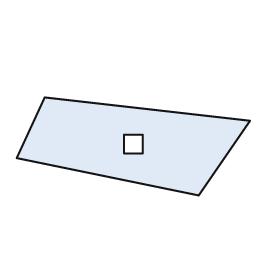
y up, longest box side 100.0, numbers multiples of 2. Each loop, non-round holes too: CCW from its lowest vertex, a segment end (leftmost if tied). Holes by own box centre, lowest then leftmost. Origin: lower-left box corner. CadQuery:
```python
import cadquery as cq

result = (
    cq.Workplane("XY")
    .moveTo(78.0, 0.0)
    .lineTo(100.0, 32.0)
    .lineTo(12.0, 42.0)
    .lineTo(0.0, 16.0)
    .close()
    .moveTo(46.0, 18.0)
    .lineTo(54.0, 18.0)
    .lineTo(54.0, 26.0)
    .lineTo(46.0, 26.0)
    .close()
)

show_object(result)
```